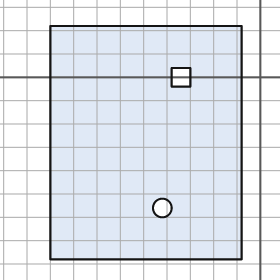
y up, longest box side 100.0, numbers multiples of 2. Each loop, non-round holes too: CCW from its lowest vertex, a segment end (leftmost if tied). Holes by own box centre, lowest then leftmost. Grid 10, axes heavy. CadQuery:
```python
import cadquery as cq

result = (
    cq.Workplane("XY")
    .moveTo(-90.0, -78.0)
    .lineTo(-8.0, -78.0)
    .lineTo(-8.0, 22.0)
    .lineTo(-90.0, 22.0)
    .close()
    .moveTo(-42.0, -56.0)
    .circle(4.0)
    .moveTo(-38.0, -4.0)
    .lineTo(-30.0, -4.0)
    .lineTo(-30.0, 4.0)
    .lineTo(-38.0, 4.0)
    .close()
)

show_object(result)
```